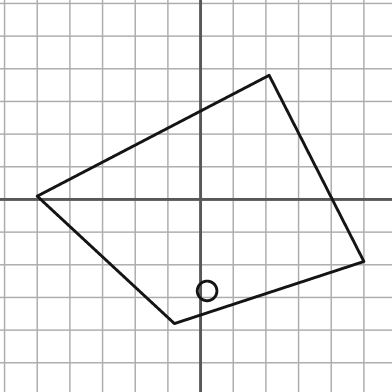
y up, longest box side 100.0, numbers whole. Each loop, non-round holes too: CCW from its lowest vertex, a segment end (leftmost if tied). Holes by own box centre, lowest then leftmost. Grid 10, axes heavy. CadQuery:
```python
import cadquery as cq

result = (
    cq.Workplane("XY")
    .moveTo(-8.0, -38.0)
    .lineTo(50.0, -19.0)
    .lineTo(21.0, 38.0)
    .lineTo(-50.0, 1.0)
    .close()
    .moveTo(2.0, -28.0)
    .circle(3.0)
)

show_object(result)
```